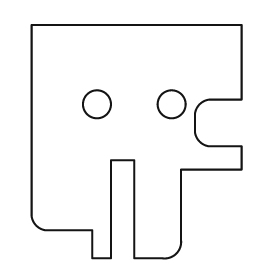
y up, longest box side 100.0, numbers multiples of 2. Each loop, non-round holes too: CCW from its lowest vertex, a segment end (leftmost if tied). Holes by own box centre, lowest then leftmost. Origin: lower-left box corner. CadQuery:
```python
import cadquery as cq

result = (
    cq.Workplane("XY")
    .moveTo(26.0, 0.0)
    .lineTo(34.0, 0.0)
    .lineTo(34.0, 42.0)
    .lineTo(44.0, 42.0)
    .lineTo(44.0, 0.0)
    .lineTo(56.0, 0.0)
    .threePointArc((62.0, 2.0), (64.0, 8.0))
    .lineTo(64.0, 38.0)
    .lineTo(90.0, 38.0)
    .lineTo(90.0, 48.0)
    .lineTo(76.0, 48.0)
    .threePointArc((72.0, 50.0), (70.0, 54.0))
    .lineTo(70.0, 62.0)
    .threePointArc((72.0, 66.0), (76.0, 68.0))
    .lineTo(90.0, 68.0)
    .lineTo(90.0, 100.0)
    .lineTo(0.0, 100.0)
    .lineTo(0.0, 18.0)
    .threePointArc((2.0, 14.0), (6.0, 12.0))
    .lineTo(26.0, 12.0)
    .close()
    .moveTo(28.0, 66.0)
    .circle(6.0)
    .moveTo(60.0, 66.0)
    .circle(6.0)
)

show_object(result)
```